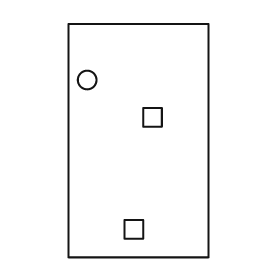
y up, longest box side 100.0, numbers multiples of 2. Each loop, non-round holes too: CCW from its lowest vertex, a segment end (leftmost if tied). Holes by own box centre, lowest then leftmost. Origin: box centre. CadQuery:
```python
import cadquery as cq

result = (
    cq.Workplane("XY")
    .moveTo(-30.0, -50.0)
    .lineTo(30.0, -50.0)
    .lineTo(30.0, 50.0)
    .lineTo(-30.0, 50.0)
    .close()
    .moveTo(-6.0, -42.0)
    .lineTo(2.0, -42.0)
    .lineTo(2.0, -34.0)
    .lineTo(-6.0, -34.0)
    .close()
    .moveTo(2.0, 6.0)
    .lineTo(10.0, 6.0)
    .lineTo(10.0, 14.0)
    .lineTo(2.0, 14.0)
    .close()
    .moveTo(-22.0, 26.0)
    .circle(4.0)
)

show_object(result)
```